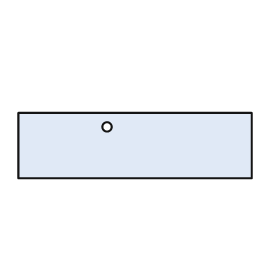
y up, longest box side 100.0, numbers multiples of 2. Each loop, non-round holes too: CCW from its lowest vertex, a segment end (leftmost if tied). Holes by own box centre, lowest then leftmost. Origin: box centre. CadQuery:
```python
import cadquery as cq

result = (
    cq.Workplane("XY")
    .moveTo(-50.0, -14.0)
    .lineTo(50.0, -14.0)
    .lineTo(50.0, 14.0)
    .lineTo(-50.0, 14.0)
    .close()
    .moveTo(-12.0, 8.0)
    .circle(2.0)
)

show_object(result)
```